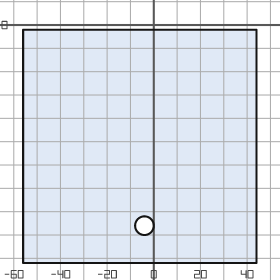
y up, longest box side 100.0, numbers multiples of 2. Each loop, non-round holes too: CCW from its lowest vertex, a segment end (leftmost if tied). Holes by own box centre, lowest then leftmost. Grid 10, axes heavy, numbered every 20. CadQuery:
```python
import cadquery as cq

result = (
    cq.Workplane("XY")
    .moveTo(-56.0, -102.0)
    .lineTo(44.0, -102.0)
    .lineTo(44.0, -2.0)
    .lineTo(-56.0, -2.0)
    .close()
    .moveTo(-4.0, -86.0)
    .circle(4.0)
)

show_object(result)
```